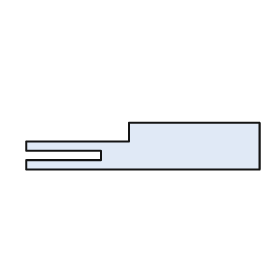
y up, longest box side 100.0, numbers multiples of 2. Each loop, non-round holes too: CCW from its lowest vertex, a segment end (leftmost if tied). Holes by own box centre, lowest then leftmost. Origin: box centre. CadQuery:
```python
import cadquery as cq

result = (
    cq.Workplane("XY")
    .moveTo(-50.0, -10.0)
    .lineTo(50.0, -10.0)
    .lineTo(50.0, 10.0)
    .lineTo(-6.0, 10.0)
    .lineTo(-6.0, 2.0)
    .lineTo(-50.0, 2.0)
    .lineTo(-50.0, -2.0)
    .lineTo(-18.0, -2.0)
    .lineTo(-18.0, -6.0)
    .lineTo(-50.0, -6.0)
    .close()
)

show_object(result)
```